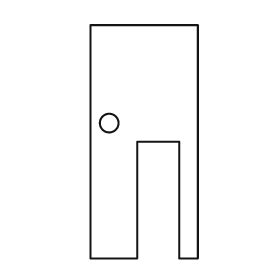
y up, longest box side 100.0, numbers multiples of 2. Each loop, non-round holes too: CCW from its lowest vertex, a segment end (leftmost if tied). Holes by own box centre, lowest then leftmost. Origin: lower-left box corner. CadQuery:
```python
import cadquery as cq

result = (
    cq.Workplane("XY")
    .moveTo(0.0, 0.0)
    .lineTo(20.0, 0.0)
    .lineTo(20.0, 50.0)
    .lineTo(38.0, 50.0)
    .lineTo(38.0, 0.0)
    .lineTo(46.0, 0.0)
    .lineTo(46.0, 100.0)
    .lineTo(0.0, 100.0)
    .close()
    .moveTo(8.0, 58.0)
    .circle(4.0)
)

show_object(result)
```